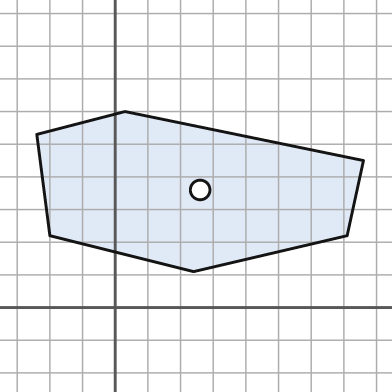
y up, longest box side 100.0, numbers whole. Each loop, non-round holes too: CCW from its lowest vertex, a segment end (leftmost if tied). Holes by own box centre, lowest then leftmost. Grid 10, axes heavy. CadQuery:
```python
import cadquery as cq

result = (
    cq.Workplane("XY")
    .moveTo(24.0, 11.0)
    .lineTo(71.0, 22.0)
    .lineTo(76.0, 45.0)
    .lineTo(3.0, 60.0)
    .lineTo(-24.0, 53.0)
    .lineTo(-20.0, 22.0)
    .close()
    .moveTo(26.0, 36.0)
    .circle(3.0)
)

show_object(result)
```